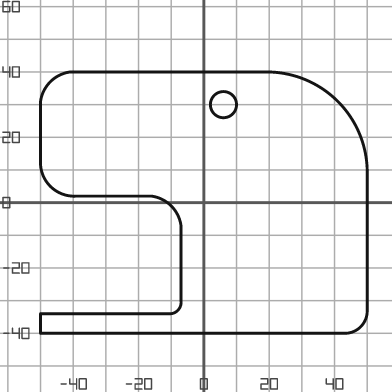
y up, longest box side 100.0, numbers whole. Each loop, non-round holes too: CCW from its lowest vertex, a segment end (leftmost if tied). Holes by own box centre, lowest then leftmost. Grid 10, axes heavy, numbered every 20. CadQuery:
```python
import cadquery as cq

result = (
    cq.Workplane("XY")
    .moveTo(-50.0, -40.0)
    .lineTo(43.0, -40.0)
    .threePointArc((48.0, -38.0), (50.0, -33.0))
    .lineTo(50.0, 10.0)
    .threePointArc((41.0, 31.0), (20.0, 40.0))
    .lineTo(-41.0, 40.0)
    .threePointArc((-47.0, 37.0), (-50.0, 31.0))
    .lineTo(-50.0, 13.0)
    .threePointArc((-47.0, 5.0), (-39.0, 2.0))
    .lineTo(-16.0, 2.0)
    .threePointArc((-10.0, -1.0), (-7.0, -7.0))
    .lineTo(-7.0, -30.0)
    .threePointArc((-8.0, -33.0), (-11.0, -34.0))
    .lineTo(-50.0, -34.0)
    .close()
    .moveTo(6.0, 30.0)
    .circle(4.0)
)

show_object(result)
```